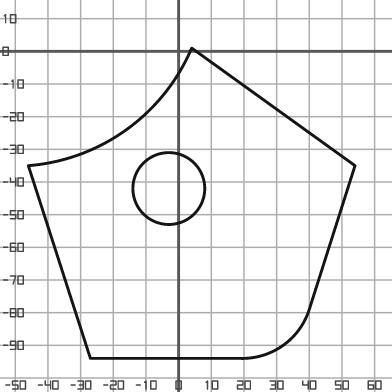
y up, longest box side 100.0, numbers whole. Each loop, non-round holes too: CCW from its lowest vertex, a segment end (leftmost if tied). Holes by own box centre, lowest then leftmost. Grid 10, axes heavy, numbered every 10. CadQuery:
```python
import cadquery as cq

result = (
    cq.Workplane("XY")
    .moveTo(-27.0, -94.0)
    .lineTo(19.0, -94.0)
    .threePointArc((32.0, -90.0), (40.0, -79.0))
    .lineTo(54.0, -35.0)
    .lineTo(4.0, 1.0)
    .threePointArc((-16.0, -24.0), (-46.0, -35.0))
    .close()
    .moveTo(-3.0, -42.0)
    .circle(11.0)
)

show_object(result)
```